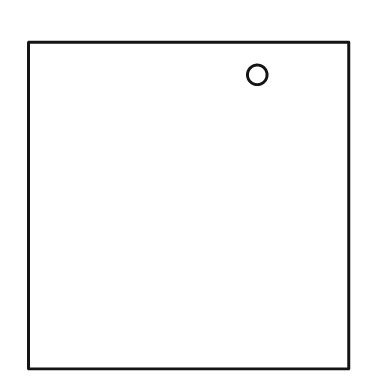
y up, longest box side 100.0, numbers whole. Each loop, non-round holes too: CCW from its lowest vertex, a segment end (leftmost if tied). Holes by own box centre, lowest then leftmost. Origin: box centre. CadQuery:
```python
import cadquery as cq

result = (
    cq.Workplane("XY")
    .moveTo(-49.0, -50.0)
    .lineTo(49.0, -50.0)
    .lineTo(49.0, 50.0)
    .lineTo(-49.0, 50.0)
    .close()
    .moveTo(21.0, 40.0)
    .circle(3.0)
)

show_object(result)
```